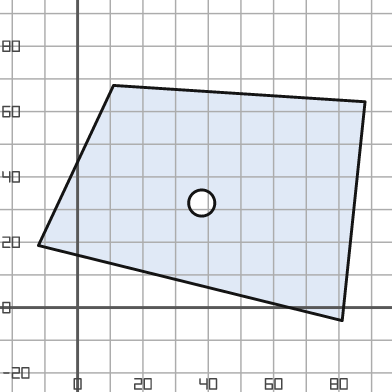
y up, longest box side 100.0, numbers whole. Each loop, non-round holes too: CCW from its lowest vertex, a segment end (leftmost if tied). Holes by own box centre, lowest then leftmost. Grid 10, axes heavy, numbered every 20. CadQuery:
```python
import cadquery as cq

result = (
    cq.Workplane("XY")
    .moveTo(81.0, -4.0)
    .lineTo(88.0, 63.0)
    .lineTo(11.0, 68.0)
    .lineTo(-12.0, 19.0)
    .close()
    .moveTo(38.0, 32.0)
    .circle(4.0)
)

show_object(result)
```